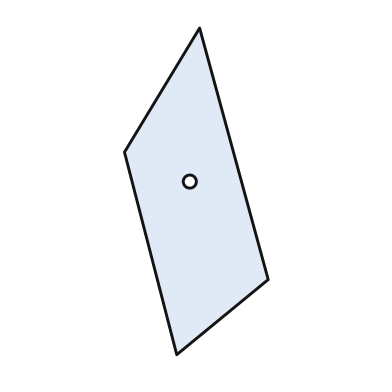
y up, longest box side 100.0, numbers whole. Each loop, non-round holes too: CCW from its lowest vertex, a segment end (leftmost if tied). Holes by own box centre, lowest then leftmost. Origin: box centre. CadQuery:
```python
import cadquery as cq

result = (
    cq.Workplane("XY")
    .moveTo(-6.0, -50.0)
    .lineTo(22.0, -27.0)
    .lineTo(1.0, 50.0)
    .lineTo(-22.0, 12.0)
    .close()
    .moveTo(-2.0, 3.0)
    .circle(2.0)
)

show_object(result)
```